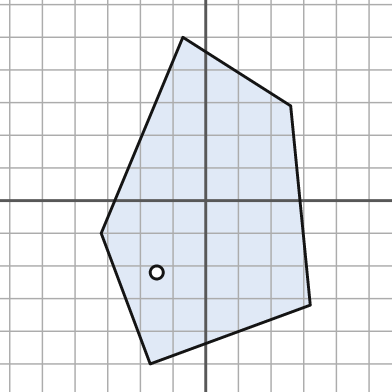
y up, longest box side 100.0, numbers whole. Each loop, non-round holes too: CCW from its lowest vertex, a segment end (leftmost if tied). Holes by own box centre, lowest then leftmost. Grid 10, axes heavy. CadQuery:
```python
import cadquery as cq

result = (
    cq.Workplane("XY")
    .moveTo(-17.0, -50.0)
    .lineTo(32.0, -32.0)
    .lineTo(26.0, 29.0)
    .lineTo(-7.0, 50.0)
    .lineTo(-32.0, -10.0)
    .close()
    .moveTo(-15.0, -22.0)
    .circle(2.0)
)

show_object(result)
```